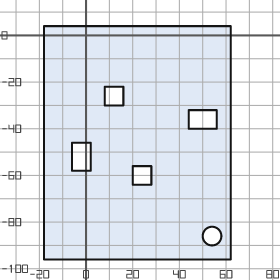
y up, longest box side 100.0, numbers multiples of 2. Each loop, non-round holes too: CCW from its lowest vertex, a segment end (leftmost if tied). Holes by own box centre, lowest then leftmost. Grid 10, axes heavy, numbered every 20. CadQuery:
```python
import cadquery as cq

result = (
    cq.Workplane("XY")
    .moveTo(-18.0, -96.0)
    .lineTo(62.0, -96.0)
    .lineTo(62.0, 4.0)
    .lineTo(-18.0, 4.0)
    .close()
    .moveTo(54.0, -86.0)
    .circle(4.0)
    .moveTo(20.0, -64.0)
    .lineTo(28.0, -64.0)
    .lineTo(28.0, -56.0)
    .lineTo(20.0, -56.0)
    .close()
    .moveTo(-6.0, -58.0)
    .lineTo(2.0, -58.0)
    .lineTo(2.0, -46.0)
    .lineTo(-6.0, -46.0)
    .close()
    .moveTo(44.0, -40.0)
    .lineTo(56.0, -40.0)
    .lineTo(56.0, -32.0)
    .lineTo(44.0, -32.0)
    .close()
    .moveTo(8.0, -30.0)
    .lineTo(16.0, -30.0)
    .lineTo(16.0, -22.0)
    .lineTo(8.0, -22.0)
    .close()
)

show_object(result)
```